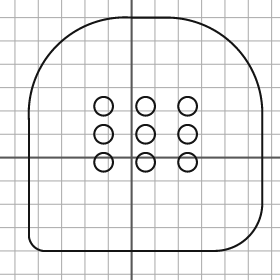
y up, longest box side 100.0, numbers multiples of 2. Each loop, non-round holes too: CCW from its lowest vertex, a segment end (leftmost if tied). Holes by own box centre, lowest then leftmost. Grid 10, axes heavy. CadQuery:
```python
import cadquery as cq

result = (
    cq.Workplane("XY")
    .moveTo(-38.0, -40.0)
    .lineTo(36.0, -40.0)
    .threePointArc((50.0, -34.0), (56.0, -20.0))
    .lineTo(56.0, 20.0)
    .threePointArc((44.0, 48.0), (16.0, 60.0))
    .lineTo(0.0, 60.0)
    .threePointArc((-32.0, 48.0), (-44.0, 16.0))
    .lineTo(-44.0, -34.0)
    .threePointArc((-42.0, -38.0), (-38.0, -40.0))
    .close()
    .moveTo(-12.0, -2.0)
    .circle(4.0)
    .moveTo(6.0, -2.0)
    .circle(4.0)
    .moveTo(24.0, -2.0)
    .circle(4.0)
    .moveTo(-12.0, 10.0)
    .circle(4.0)
    .moveTo(6.0, 10.0)
    .circle(4.0)
    .moveTo(24.0, 10.0)
    .circle(4.0)
    .moveTo(-12.0, 22.0)
    .circle(4.0)
    .moveTo(6.0, 22.0)
    .circle(4.0)
    .moveTo(24.0, 22.0)
    .circle(4.0)
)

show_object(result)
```